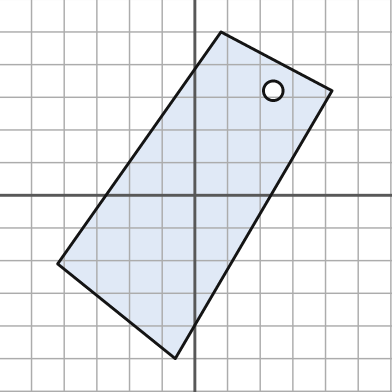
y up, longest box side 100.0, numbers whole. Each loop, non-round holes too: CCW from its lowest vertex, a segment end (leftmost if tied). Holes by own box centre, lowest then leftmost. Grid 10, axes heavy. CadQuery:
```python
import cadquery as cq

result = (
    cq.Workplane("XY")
    .moveTo(-6.0, -50.0)
    .lineTo(42.0, 32.0)
    .lineTo(8.0, 50.0)
    .lineTo(-42.0, -21.0)
    .close()
    .moveTo(24.0, 32.0)
    .circle(3.0)
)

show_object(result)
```